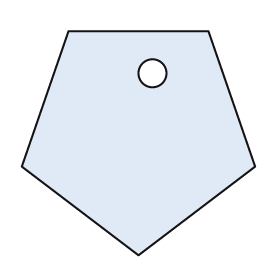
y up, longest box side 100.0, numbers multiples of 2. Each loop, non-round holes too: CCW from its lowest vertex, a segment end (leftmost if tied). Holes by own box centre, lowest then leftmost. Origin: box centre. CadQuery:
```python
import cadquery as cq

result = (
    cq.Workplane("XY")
    .moveTo(0.0, -48.0)
    .lineTo(50.0, -10.0)
    .lineTo(30.0, 48.0)
    .lineTo(-30.0, 48.0)
    .lineTo(-50.0, -10.0)
    .close()
    .moveTo(6.0, 30.0)
    .circle(6.0)
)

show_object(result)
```